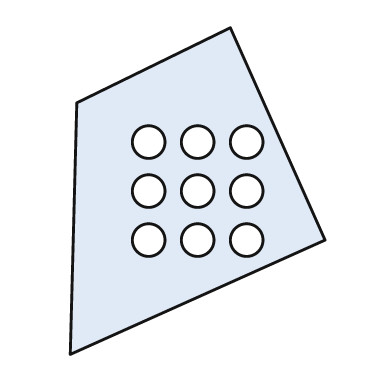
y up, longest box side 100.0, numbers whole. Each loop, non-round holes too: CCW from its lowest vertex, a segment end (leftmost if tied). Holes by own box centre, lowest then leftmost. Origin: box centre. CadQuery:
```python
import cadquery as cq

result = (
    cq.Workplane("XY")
    .moveTo(-39.0, -50.0)
    .lineTo(39.0, -15.0)
    .lineTo(10.0, 50.0)
    .lineTo(-37.0, 27.0)
    .close()
    .moveTo(-15.0, -15.0)
    .circle(5.0)
    .moveTo(0.0, -15.0)
    .circle(5.0)
    .moveTo(15.0, -15.0)
    .circle(5.0)
    .moveTo(-15.0, 0.0)
    .circle(5.0)
    .moveTo(0.0, 0.0)
    .circle(5.0)
    .moveTo(15.0, 0.0)
    .circle(5.0)
    .moveTo(-15.0, 15.0)
    .circle(5.0)
    .moveTo(0.0, 15.0)
    .circle(5.0)
    .moveTo(15.0, 15.0)
    .circle(5.0)
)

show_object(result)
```